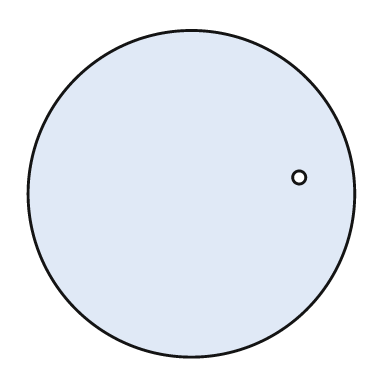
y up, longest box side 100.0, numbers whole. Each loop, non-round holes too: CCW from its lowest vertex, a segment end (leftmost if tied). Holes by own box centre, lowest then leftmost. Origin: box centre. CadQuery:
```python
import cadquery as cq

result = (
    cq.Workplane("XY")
    .moveTo(0.0, 0.0)
    .circle(50.0)
    .moveTo(33.0, 5.0)
    .circle(2.0)
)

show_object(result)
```